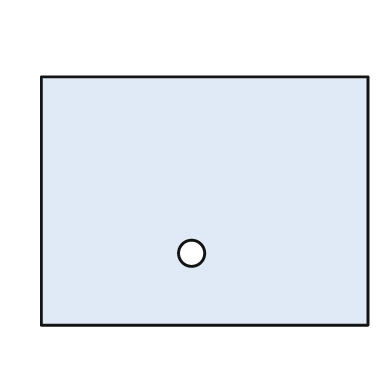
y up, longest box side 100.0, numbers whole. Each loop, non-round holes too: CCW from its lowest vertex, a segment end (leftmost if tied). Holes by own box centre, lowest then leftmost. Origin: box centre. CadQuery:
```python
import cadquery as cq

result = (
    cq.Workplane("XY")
    .moveTo(-50.0, -38.0)
    .lineTo(50.0, -38.0)
    .lineTo(50.0, 38.0)
    .lineTo(-50.0, 38.0)
    .close()
    .moveTo(-4.0, -16.0)
    .circle(4.0)
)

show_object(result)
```